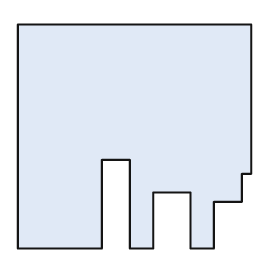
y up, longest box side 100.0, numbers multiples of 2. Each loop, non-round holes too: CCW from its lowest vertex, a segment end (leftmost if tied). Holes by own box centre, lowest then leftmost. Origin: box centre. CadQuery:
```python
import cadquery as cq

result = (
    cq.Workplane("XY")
    .moveTo(-50.0, -48.0)
    .lineTo(-14.0, -48.0)
    .lineTo(-14.0, -10.0)
    .lineTo(-2.0, -10.0)
    .lineTo(-2.0, -48.0)
    .lineTo(8.0, -48.0)
    .lineTo(8.0, -24.0)
    .lineTo(24.0, -24.0)
    .lineTo(24.0, -48.0)
    .lineTo(34.0, -48.0)
    .lineTo(34.0, -28.0)
    .lineTo(46.0, -28.0)
    .lineTo(46.0, -16.0)
    .lineTo(50.0, -16.0)
    .lineTo(50.0, 48.0)
    .lineTo(-50.0, 48.0)
    .close()
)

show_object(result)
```